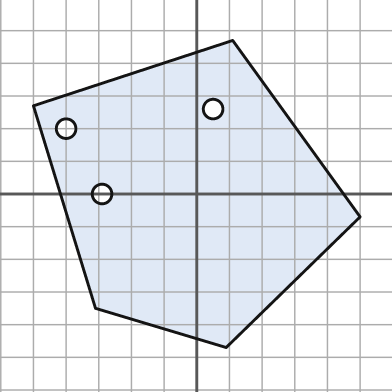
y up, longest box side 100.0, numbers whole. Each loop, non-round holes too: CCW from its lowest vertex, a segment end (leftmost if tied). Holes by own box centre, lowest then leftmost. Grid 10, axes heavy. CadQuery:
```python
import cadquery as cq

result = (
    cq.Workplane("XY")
    .moveTo(9.0, -47.0)
    .lineTo(50.0, -7.0)
    .lineTo(11.0, 47.0)
    .lineTo(-50.0, 27.0)
    .lineTo(-31.0, -35.0)
    .close()
    .moveTo(-29.0, 0.0)
    .circle(3.0)
    .moveTo(-40.0, 20.0)
    .circle(3.0)
    .moveTo(5.0, 26.0)
    .circle(3.0)
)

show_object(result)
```